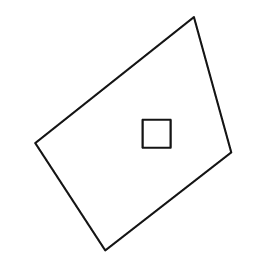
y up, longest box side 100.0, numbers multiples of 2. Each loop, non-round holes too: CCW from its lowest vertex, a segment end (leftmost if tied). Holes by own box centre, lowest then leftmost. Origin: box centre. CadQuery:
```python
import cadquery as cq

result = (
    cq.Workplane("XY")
    .moveTo(-12.0, -50.0)
    .lineTo(42.0, -8.0)
    .lineTo(26.0, 50.0)
    .lineTo(-42.0, -4.0)
    .close()
    .moveTo(4.0, -6.0)
    .lineTo(16.0, -6.0)
    .lineTo(16.0, 6.0)
    .lineTo(4.0, 6.0)
    .close()
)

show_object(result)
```